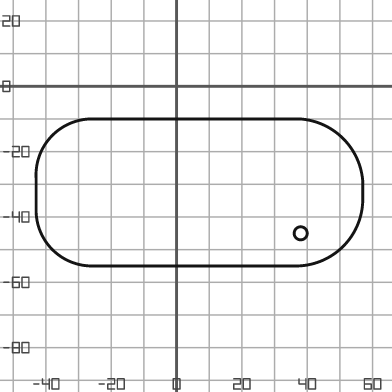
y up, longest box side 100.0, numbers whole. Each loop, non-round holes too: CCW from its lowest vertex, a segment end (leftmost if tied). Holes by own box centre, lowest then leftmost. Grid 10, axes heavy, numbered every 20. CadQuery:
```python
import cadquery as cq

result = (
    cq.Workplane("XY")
    .moveTo(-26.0, -55.0)
    .lineTo(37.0, -55.0)
    .threePointArc((51.0, -49.0), (57.0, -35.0))
    .lineTo(57.0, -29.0)
    .threePointArc((51.0, -16.0), (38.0, -10.0))
    .lineTo(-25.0, -10.0)
    .threePointArc((-38.0, -15.0), (-43.0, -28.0))
    .lineTo(-43.0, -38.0)
    .threePointArc((-38.0, -50.0), (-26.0, -55.0))
    .close()
    .moveTo(38.0, -45.0)
    .circle(2.0)
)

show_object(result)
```